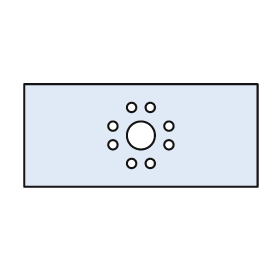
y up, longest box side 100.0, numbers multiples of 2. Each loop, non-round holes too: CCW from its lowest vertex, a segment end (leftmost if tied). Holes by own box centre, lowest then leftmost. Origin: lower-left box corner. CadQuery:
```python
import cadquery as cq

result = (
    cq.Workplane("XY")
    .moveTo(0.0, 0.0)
    .lineTo(100.0, 0.0)
    .lineTo(100.0, 44.0)
    .lineTo(0.0, 44.0)
    .close()
    .moveTo(46.0, 10.0)
    .circle(2.0)
    .moveTo(54.0, 10.0)
    .circle(2.0)
    .moveTo(38.0, 18.0)
    .circle(2.0)
    .moveTo(62.0, 18.0)
    .circle(2.0)
    .moveTo(50.0, 22.0)
    .circle(6.0)
    .moveTo(38.0, 26.0)
    .circle(2.0)
    .moveTo(62.0, 26.0)
    .circle(2.0)
    .moveTo(46.0, 34.0)
    .circle(2.0)
    .moveTo(54.0, 34.0)
    .circle(2.0)
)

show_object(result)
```